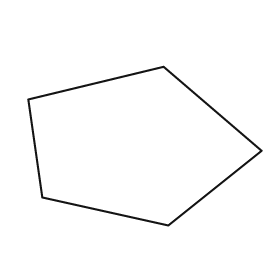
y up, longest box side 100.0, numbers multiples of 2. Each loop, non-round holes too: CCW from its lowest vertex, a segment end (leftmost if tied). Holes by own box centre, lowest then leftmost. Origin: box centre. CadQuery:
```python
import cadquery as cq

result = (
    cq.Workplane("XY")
    .moveTo(10.0, -34.0)
    .lineTo(50.0, -2.0)
    .lineTo(8.0, 34.0)
    .lineTo(-50.0, 20.0)
    .lineTo(-44.0, -22.0)
    .close()
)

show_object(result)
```